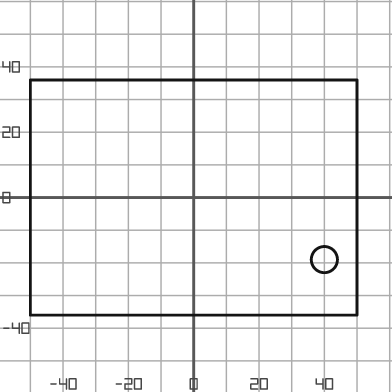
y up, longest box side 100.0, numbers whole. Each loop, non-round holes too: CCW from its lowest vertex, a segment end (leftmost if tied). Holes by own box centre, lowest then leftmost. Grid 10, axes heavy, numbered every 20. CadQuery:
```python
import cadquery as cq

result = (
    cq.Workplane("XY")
    .moveTo(-50.0, -36.0)
    .lineTo(50.0, -36.0)
    .lineTo(50.0, 36.0)
    .lineTo(-50.0, 36.0)
    .close()
    .moveTo(40.0, -19.0)
    .circle(4.0)
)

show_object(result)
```